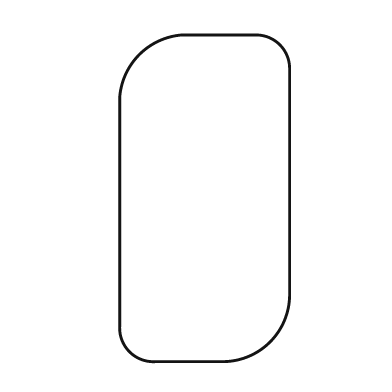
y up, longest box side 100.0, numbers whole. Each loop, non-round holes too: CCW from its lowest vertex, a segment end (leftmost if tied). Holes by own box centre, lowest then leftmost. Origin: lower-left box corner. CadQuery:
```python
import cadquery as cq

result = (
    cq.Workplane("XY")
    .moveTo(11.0, 0.0)
    .lineTo(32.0, 0.0)
    .threePointArc((46.0, 6.0), (52.0, 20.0))
    .lineTo(52.0, 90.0)
    .threePointArc((49.0, 97.0), (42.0, 100.0))
    .lineTo(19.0, 100.0)
    .threePointArc((6.0, 94.0), (0.0, 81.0))
    .lineTo(0.0, 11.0)
    .threePointArc((3.0, 3.0), (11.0, 0.0))
    .close()
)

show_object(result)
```